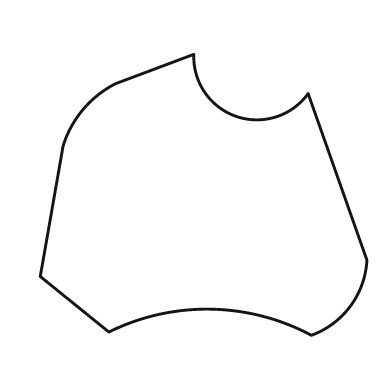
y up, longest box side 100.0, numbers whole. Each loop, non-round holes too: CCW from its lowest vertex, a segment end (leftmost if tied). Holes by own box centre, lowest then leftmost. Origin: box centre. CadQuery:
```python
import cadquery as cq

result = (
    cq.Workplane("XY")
    .moveTo(33.0, -43.0)
    .threePointArc((45.0, -34.0), (50.0, -20.0))
    .lineTo(32.0, 31.0)
    .threePointArc((10.0, 24.0), (-3.0, 43.0))
    .lineTo(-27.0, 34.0)
    .threePointArc((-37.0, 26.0), (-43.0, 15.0))
    .lineTo(-50.0, -25.0)
    .lineTo(-29.0, -42.0)
    .threePointArc((2.0, -35.0), (33.0, -43.0))
    .close()
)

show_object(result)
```